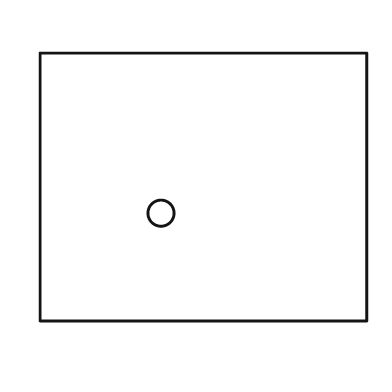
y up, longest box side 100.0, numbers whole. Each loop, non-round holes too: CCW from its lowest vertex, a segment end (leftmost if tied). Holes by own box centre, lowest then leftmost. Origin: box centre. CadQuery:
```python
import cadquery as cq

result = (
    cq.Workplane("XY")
    .moveTo(-50.0, -41.0)
    .lineTo(50.0, -41.0)
    .lineTo(50.0, 41.0)
    .lineTo(-50.0, 41.0)
    .close()
    .moveTo(-13.0, -8.0)
    .circle(4.0)
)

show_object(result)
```